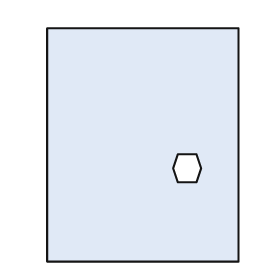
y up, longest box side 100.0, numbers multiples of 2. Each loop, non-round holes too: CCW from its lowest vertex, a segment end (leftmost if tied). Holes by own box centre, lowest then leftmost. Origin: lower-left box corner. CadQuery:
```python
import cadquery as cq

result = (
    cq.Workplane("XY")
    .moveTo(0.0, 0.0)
    .lineTo(82.0, 0.0)
    .lineTo(82.0, 100.0)
    .lineTo(0.0, 100.0)
    .close()
    .moveTo(56.0, 34.0)
    .lineTo(64.0, 34.0)
    .lineTo(66.0, 40.0)
    .lineTo(64.0, 46.0)
    .lineTo(56.0, 46.0)
    .lineTo(54.0, 40.0)
    .close()
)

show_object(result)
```